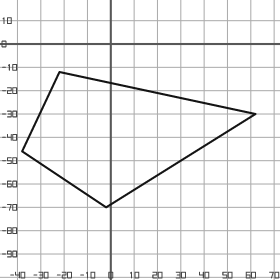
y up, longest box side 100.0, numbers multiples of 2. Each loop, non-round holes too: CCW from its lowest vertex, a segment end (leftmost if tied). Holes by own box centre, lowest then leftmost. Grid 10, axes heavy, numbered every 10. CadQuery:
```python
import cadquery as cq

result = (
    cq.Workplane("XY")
    .moveTo(-2.0, -70.0)
    .lineTo(62.0, -30.0)
    .lineTo(-22.0, -12.0)
    .lineTo(-38.0, -46.0)
    .close()
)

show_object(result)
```